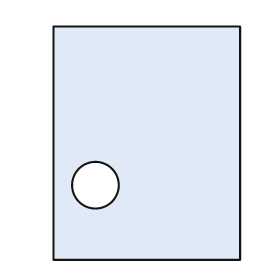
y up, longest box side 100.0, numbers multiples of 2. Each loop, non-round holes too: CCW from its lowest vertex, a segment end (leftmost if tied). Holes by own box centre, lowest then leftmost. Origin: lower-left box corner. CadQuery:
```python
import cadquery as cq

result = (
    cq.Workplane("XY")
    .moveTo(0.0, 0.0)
    .lineTo(80.0, 0.0)
    .lineTo(80.0, 100.0)
    .lineTo(0.0, 100.0)
    .close()
    .moveTo(18.0, 32.0)
    .circle(10.0)
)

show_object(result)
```